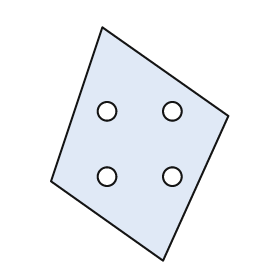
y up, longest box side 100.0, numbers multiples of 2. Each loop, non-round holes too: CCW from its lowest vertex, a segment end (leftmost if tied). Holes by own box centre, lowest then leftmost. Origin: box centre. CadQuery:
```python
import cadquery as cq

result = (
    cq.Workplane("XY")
    .moveTo(10.0, -50.0)
    .lineTo(38.0, 12.0)
    .lineTo(-16.0, 50.0)
    .lineTo(-38.0, -16.0)
    .close()
    .moveTo(-14.0, -14.0)
    .circle(4.0)
    .moveTo(14.0, -14.0)
    .circle(4.0)
    .moveTo(-14.0, 14.0)
    .circle(4.0)
    .moveTo(14.0, 14.0)
    .circle(4.0)
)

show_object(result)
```